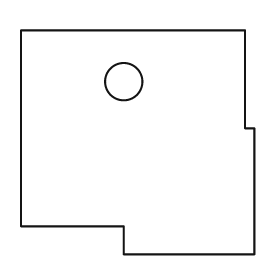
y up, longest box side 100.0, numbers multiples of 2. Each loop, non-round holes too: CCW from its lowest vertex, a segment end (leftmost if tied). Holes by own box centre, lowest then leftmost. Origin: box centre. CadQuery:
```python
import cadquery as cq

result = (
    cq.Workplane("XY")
    .moveTo(-6.0, -48.0)
    .lineTo(50.0, -48.0)
    .lineTo(50.0, 6.0)
    .lineTo(46.0, 6.0)
    .lineTo(46.0, 48.0)
    .lineTo(-50.0, 48.0)
    .lineTo(-50.0, -36.0)
    .lineTo(-6.0, -36.0)
    .close()
    .moveTo(-6.0, 26.0)
    .circle(8.0)
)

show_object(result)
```